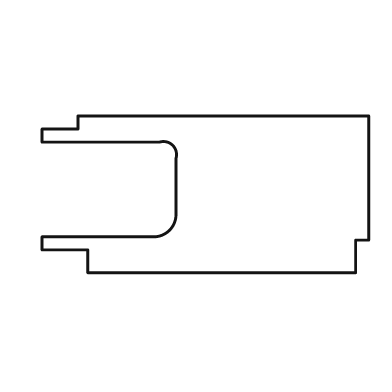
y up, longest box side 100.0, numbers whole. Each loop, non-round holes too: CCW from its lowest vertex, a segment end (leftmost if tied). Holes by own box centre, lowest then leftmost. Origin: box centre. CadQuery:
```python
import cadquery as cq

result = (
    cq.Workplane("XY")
    .moveTo(-36.0, -24.0)
    .lineTo(46.0, -24.0)
    .lineTo(46.0, -14.0)
    .lineTo(50.0, -14.0)
    .lineTo(50.0, 24.0)
    .lineTo(-39.0, 24.0)
    .lineTo(-39.0, 20.0)
    .lineTo(-50.0, 20.0)
    .lineTo(-50.0, 16.0)
    .lineTo(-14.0, 16.0)
    .threePointArc((-10.0, 15.0), (-9.0, 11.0))
    .lineTo(-9.0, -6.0)
    .threePointArc((-11.0, -11.0), (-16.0, -13.0))
    .lineTo(-50.0, -13.0)
    .lineTo(-50.0, -17.0)
    .lineTo(-36.0, -17.0)
    .close()
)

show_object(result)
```